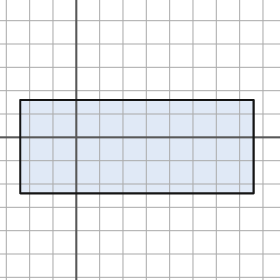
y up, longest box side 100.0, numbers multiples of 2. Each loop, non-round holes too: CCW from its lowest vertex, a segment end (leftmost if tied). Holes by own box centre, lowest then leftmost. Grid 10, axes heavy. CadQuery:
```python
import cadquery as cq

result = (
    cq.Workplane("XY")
    .moveTo(-24.0, -24.0)
    .lineTo(76.0, -24.0)
    .lineTo(76.0, 16.0)
    .lineTo(-24.0, 16.0)
    .close()
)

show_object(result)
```